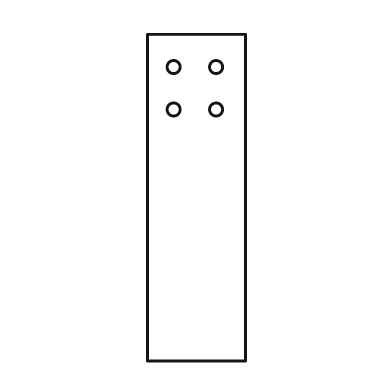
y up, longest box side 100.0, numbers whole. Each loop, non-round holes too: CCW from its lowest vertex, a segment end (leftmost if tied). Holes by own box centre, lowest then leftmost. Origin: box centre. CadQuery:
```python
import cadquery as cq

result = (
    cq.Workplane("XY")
    .moveTo(-15.0, -50.0)
    .lineTo(15.0, -50.0)
    .lineTo(15.0, 50.0)
    .lineTo(-15.0, 50.0)
    .close()
    .moveTo(-7.0, 27.0)
    .circle(2.0)
    .moveTo(6.0, 27.0)
    .circle(2.0)
    .moveTo(-7.0, 40.0)
    .circle(2.0)
    .moveTo(6.0, 40.0)
    .circle(2.0)
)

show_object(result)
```